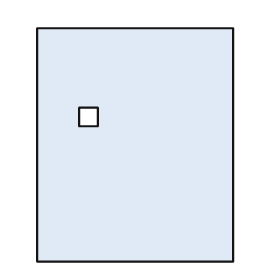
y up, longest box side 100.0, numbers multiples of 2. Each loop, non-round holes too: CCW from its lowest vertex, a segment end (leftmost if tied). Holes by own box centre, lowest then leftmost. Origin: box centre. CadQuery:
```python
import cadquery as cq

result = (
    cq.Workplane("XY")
    .moveTo(-42.0, -50.0)
    .lineTo(42.0, -50.0)
    .lineTo(42.0, 50.0)
    .lineTo(-42.0, 50.0)
    .close()
    .moveTo(-24.0, 8.0)
    .lineTo(-16.0, 8.0)
    .lineTo(-16.0, 16.0)
    .lineTo(-24.0, 16.0)
    .close()
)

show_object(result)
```